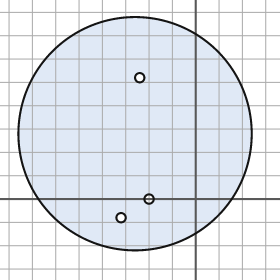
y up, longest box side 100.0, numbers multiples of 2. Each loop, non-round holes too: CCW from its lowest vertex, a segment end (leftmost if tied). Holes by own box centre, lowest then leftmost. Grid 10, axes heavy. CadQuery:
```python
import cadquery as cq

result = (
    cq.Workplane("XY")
    .moveTo(-26.0, 28.0)
    .circle(50.0)
    .moveTo(-32.0, -8.0)
    .circle(2.0)
    .moveTo(-20.0, 0.0)
    .circle(2.0)
    .moveTo(-24.0, 52.0)
    .circle(2.0)
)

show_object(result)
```